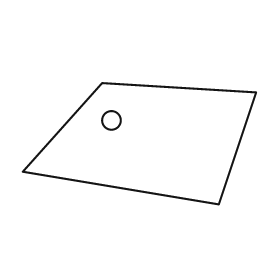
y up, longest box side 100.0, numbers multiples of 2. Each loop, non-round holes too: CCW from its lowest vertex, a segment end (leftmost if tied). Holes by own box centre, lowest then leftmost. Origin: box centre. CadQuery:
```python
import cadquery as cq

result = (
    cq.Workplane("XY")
    .moveTo(34.0, -26.0)
    .lineTo(50.0, 22.0)
    .lineTo(-16.0, 26.0)
    .lineTo(-50.0, -12.0)
    .close()
    .moveTo(-12.0, 10.0)
    .circle(4.0)
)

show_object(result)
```